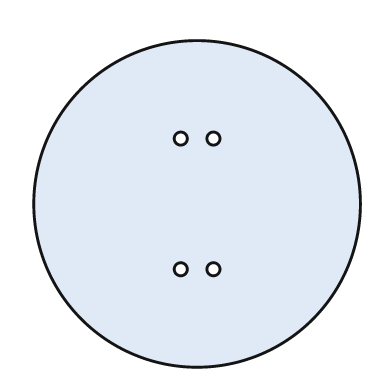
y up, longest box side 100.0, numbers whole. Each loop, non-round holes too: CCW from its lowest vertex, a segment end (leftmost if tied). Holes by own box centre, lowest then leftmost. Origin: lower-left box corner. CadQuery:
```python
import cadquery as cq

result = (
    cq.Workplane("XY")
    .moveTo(50.0, 50.0)
    .circle(50.0)
    .moveTo(45.0, 30.0)
    .circle(2.0)
    .moveTo(55.0, 30.0)
    .circle(2.0)
    .moveTo(45.0, 70.0)
    .circle(2.0)
    .moveTo(55.0, 70.0)
    .circle(2.0)
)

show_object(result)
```